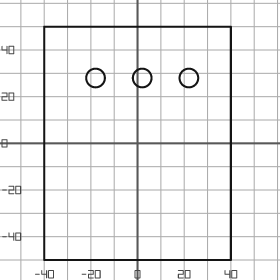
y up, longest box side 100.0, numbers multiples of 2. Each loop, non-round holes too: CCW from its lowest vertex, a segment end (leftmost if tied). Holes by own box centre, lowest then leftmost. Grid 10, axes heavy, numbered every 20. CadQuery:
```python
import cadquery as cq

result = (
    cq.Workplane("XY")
    .moveTo(-40.0, -50.0)
    .lineTo(40.0, -50.0)
    .lineTo(40.0, 50.0)
    .lineTo(-40.0, 50.0)
    .close()
    .moveTo(-18.0, 28.0)
    .circle(4.0)
    .moveTo(2.0, 28.0)
    .circle(4.0)
    .moveTo(22.0, 28.0)
    .circle(4.0)
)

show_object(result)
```